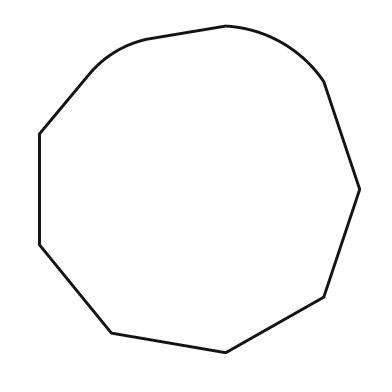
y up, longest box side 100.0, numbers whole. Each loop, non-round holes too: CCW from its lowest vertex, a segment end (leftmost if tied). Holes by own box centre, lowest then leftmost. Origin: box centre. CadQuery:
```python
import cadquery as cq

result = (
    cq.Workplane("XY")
    .moveTo(8.0, -50.0)
    .lineTo(38.0, -33.0)
    .lineTo(49.0, 0.0)
    .lineTo(38.0, 33.0)
    .threePointArc((25.0, 45.0), (8.0, 50.0))
    .lineTo(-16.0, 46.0)
    .threePointArc((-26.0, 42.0), (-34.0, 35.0))
    .lineTo(-49.0, 17.0)
    .lineTo(-49.0, -17.0)
    .lineTo(-27.0, -44.0)
    .close()
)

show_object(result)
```